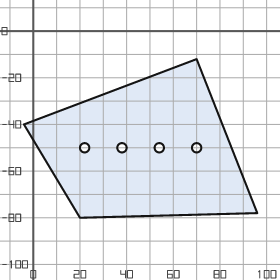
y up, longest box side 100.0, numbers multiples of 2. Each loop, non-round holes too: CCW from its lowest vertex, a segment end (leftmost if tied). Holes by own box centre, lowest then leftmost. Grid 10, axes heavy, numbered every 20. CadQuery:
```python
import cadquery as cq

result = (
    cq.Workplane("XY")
    .moveTo(20.0, -80.0)
    .lineTo(96.0, -78.0)
    .lineTo(70.0, -12.0)
    .lineTo(-4.0, -40.0)
    .close()
    .moveTo(22.0, -50.0)
    .circle(2.0)
    .moveTo(38.0, -50.0)
    .circle(2.0)
    .moveTo(54.0, -50.0)
    .circle(2.0)
    .moveTo(70.0, -50.0)
    .circle(2.0)
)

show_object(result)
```